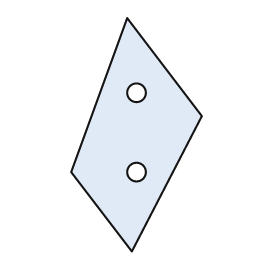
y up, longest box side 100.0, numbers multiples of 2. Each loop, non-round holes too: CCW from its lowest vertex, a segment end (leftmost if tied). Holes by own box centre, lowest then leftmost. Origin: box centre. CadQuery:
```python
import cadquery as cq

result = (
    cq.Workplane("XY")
    .moveTo(-2.0, -50.0)
    .lineTo(28.0, 8.0)
    .lineTo(-4.0, 50.0)
    .lineTo(-28.0, -16.0)
    .close()
    .moveTo(0.0, -16.0)
    .circle(4.0)
    .moveTo(0.0, 18.0)
    .circle(4.0)
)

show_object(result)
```